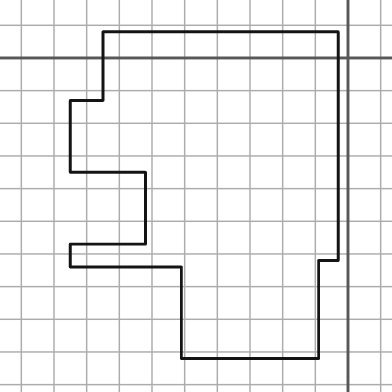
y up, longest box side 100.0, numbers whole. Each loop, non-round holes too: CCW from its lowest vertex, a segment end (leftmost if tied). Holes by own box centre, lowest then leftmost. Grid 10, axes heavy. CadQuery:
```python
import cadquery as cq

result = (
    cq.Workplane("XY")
    .moveTo(-51.0, -92.0)
    .lineTo(-9.0, -92.0)
    .lineTo(-9.0, -62.0)
    .lineTo(-3.0, -62.0)
    .lineTo(-3.0, 8.0)
    .lineTo(-75.0, 8.0)
    .lineTo(-75.0, -13.0)
    .lineTo(-85.0, -13.0)
    .lineTo(-85.0, -35.0)
    .lineTo(-62.0, -35.0)
    .lineTo(-62.0, -57.0)
    .lineTo(-85.0, -57.0)
    .lineTo(-85.0, -64.0)
    .lineTo(-51.0, -64.0)
    .close()
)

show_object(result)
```